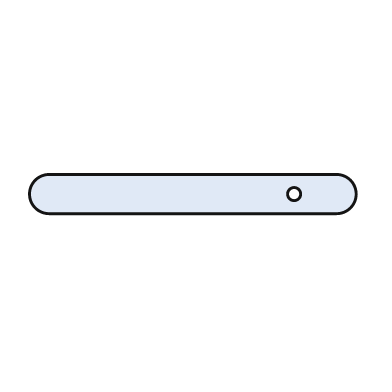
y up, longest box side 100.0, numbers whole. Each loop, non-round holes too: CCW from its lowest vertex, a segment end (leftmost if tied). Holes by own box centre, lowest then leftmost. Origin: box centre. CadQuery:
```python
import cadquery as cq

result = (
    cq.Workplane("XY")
    .moveTo(-44.0, -6.0)
    .lineTo(44.0, -6.0)
    .threePointArc((50.0, 0.0), (44.0, 6.0))
    .lineTo(-44.0, 6.0)
    .threePointArc((-50.0, 0.0), (-44.0, -6.0))
    .close()
    .moveTo(31.0, 0.0)
    .circle(2.0)
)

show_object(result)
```